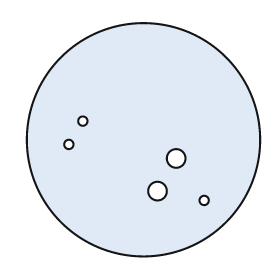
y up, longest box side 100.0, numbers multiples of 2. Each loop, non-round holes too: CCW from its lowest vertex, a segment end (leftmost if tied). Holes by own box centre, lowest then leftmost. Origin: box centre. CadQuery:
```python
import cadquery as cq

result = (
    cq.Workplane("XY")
    .moveTo(0.0, 0.0)
    .circle(50.0)
    .moveTo(26.0, -26.0)
    .circle(2.0)
    .moveTo(6.0, -22.0)
    .circle(4.0)
    .moveTo(14.0, -8.0)
    .circle(4.0)
    .moveTo(-32.0, -2.0)
    .circle(2.0)
    .moveTo(-26.0, 8.0)
    .circle(2.0)
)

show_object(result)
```